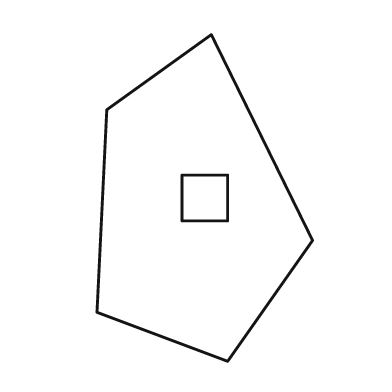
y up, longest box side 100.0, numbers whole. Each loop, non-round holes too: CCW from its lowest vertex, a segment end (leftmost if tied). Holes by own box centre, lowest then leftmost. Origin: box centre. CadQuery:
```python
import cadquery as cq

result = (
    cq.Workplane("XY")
    .moveTo(7.0, -50.0)
    .lineTo(33.0, -13.0)
    .lineTo(2.0, 50.0)
    .lineTo(-30.0, 27.0)
    .lineTo(-33.0, -35.0)
    .close()
    .moveTo(-7.0, -7.0)
    .lineTo(7.0, -7.0)
    .lineTo(7.0, 7.0)
    .lineTo(-7.0, 7.0)
    .close()
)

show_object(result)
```